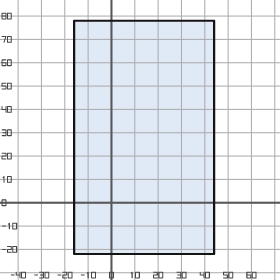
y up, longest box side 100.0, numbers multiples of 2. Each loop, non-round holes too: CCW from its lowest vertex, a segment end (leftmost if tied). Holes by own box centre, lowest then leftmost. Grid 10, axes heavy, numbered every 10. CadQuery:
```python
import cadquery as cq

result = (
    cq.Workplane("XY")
    .moveTo(-16.0, -22.0)
    .lineTo(44.0, -22.0)
    .lineTo(44.0, 78.0)
    .lineTo(-16.0, 78.0)
    .close()
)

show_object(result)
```